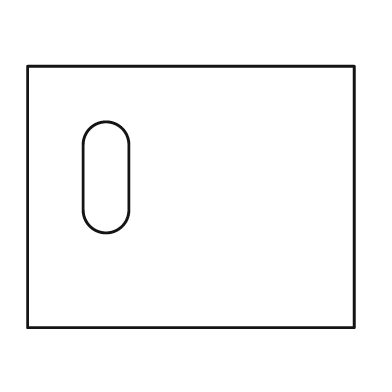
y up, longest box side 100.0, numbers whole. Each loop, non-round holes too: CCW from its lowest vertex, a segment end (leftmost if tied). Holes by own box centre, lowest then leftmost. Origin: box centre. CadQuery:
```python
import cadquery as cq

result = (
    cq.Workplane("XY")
    .moveTo(-50.0, -40.0)
    .lineTo(50.0, -40.0)
    .lineTo(50.0, 40.0)
    .lineTo(-50.0, 40.0)
    .close()
    .moveTo(-33.0, -4.0)
    .threePointArc((-26.0, -11.0), (-19.0, -4.0))
    .lineTo(-19.0, 16.0)
    .threePointArc((-26.0, 23.0), (-33.0, 16.0))
    .close()
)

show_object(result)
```